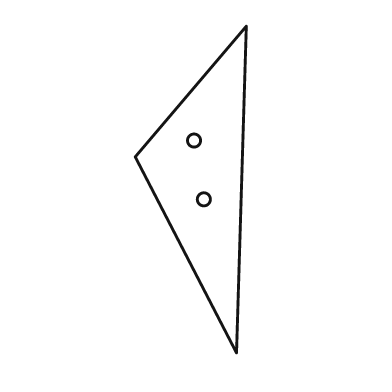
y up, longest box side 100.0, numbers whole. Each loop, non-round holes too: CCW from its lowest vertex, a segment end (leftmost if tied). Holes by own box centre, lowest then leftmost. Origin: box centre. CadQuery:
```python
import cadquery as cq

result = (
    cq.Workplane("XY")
    .moveTo(14.0, -50.0)
    .lineTo(17.0, 50.0)
    .lineTo(-17.0, 10.0)
    .close()
    .moveTo(4.0, -3.0)
    .circle(2.0)
    .moveTo(1.0, 15.0)
    .circle(2.0)
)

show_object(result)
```